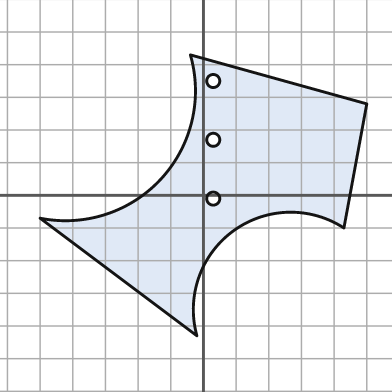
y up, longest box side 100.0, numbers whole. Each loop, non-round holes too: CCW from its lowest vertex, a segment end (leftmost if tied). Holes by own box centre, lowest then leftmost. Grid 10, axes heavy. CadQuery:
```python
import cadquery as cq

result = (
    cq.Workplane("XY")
    .moveTo(-2.0, -43.0)
    .threePointArc((9.0, -11.0), (43.0, -10.0))
    .lineTo(50.0, 28.0)
    .lineTo(-4.0, 43.0)
    .threePointArc((-13.0, 5.0), (-50.0, -7.0))
    .close()
    .moveTo(3.0, -1.0)
    .circle(2.0)
    .moveTo(3.0, 17.0)
    .circle(2.0)
    .moveTo(3.0, 35.0)
    .circle(2.0)
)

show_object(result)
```